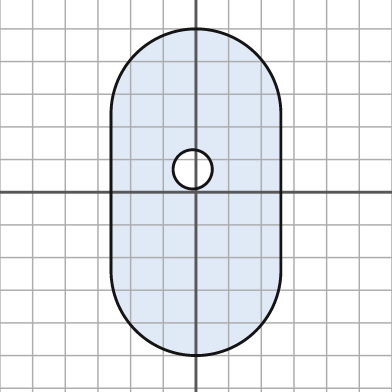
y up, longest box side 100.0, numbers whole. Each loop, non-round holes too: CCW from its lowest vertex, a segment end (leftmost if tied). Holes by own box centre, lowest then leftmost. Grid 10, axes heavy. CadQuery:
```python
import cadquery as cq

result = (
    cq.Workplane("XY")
    .moveTo(-26.0, -24.0)
    .threePointArc((0.0, -50.0), (26.0, -24.0))
    .lineTo(26.0, 24.0)
    .threePointArc((0.0, 50.0), (-26.0, 24.0))
    .close()
    .moveTo(-1.0, 7.0)
    .circle(6.0)
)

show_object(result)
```